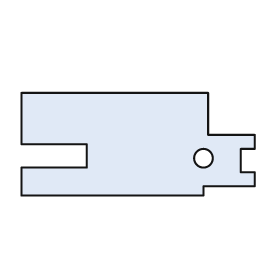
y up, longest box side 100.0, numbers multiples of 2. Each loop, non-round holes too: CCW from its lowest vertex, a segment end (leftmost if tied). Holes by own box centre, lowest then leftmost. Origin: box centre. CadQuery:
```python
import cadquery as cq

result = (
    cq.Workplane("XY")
    .moveTo(-50.0, -22.0)
    .lineTo(28.0, -22.0)
    .lineTo(28.0, -18.0)
    .lineTo(50.0, -18.0)
    .lineTo(50.0, -12.0)
    .lineTo(44.0, -12.0)
    .lineTo(44.0, -2.0)
    .lineTo(50.0, -2.0)
    .lineTo(50.0, 4.0)
    .lineTo(30.0, 4.0)
    .lineTo(30.0, 22.0)
    .lineTo(-50.0, 22.0)
    .lineTo(-50.0, 0.0)
    .lineTo(-22.0, 0.0)
    .lineTo(-22.0, -10.0)
    .lineTo(-50.0, -10.0)
    .close()
    .moveTo(28.0, -6.0)
    .circle(4.0)
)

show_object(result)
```